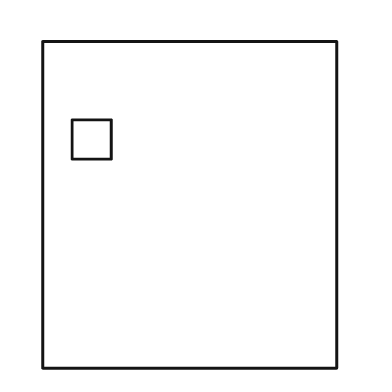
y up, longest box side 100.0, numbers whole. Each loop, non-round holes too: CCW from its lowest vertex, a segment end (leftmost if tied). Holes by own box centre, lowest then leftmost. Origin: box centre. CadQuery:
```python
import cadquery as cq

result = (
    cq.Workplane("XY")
    .moveTo(-45.0, -50.0)
    .lineTo(45.0, -50.0)
    .lineTo(45.0, 50.0)
    .lineTo(-45.0, 50.0)
    .close()
    .moveTo(-36.0, 14.0)
    .lineTo(-24.0, 14.0)
    .lineTo(-24.0, 26.0)
    .lineTo(-36.0, 26.0)
    .close()
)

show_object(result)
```